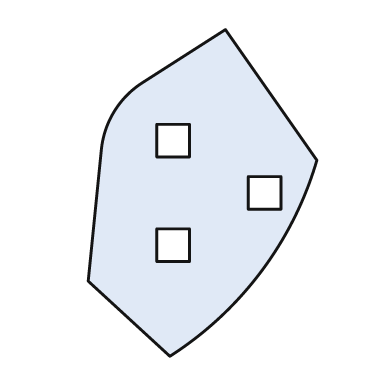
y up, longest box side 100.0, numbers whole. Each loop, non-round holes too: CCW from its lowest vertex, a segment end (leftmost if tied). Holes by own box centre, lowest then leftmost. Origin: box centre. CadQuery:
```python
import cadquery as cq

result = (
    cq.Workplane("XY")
    .moveTo(-10.0, -50.0)
    .threePointArc((18.0, -24.0), (35.0, 10.0))
    .lineTo(7.0, 50.0)
    .lineTo(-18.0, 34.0)
    .threePointArc((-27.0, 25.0), (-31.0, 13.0))
    .lineTo(-35.0, -27.0)
    .close()
    .moveTo(-14.0, -21.0)
    .lineTo(-4.0, -21.0)
    .lineTo(-4.0, -11.0)
    .lineTo(-14.0, -11.0)
    .close()
    .moveTo(14.0, -5.0)
    .lineTo(24.0, -5.0)
    .lineTo(24.0, 5.0)
    .lineTo(14.0, 5.0)
    .close()
    .moveTo(-14.0, 11.0)
    .lineTo(-4.0, 11.0)
    .lineTo(-4.0, 21.0)
    .lineTo(-14.0, 21.0)
    .close()
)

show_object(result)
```